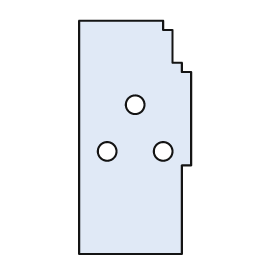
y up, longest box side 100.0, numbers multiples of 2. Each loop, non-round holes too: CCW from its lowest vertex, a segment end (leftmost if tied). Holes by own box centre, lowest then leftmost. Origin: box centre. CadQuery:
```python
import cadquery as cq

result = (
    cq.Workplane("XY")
    .moveTo(-24.0, -50.0)
    .lineTo(20.0, -50.0)
    .lineTo(20.0, -12.0)
    .lineTo(24.0, -12.0)
    .lineTo(24.0, 28.0)
    .lineTo(20.0, 28.0)
    .lineTo(20.0, 32.0)
    .lineTo(16.0, 32.0)
    .lineTo(16.0, 46.0)
    .lineTo(12.0, 46.0)
    .lineTo(12.0, 50.0)
    .lineTo(-24.0, 50.0)
    .close()
    .moveTo(-12.0, -6.0)
    .circle(4.0)
    .moveTo(12.0, -6.0)
    .circle(4.0)
    .moveTo(0.0, 14.0)
    .circle(4.0)
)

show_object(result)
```